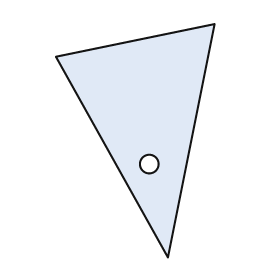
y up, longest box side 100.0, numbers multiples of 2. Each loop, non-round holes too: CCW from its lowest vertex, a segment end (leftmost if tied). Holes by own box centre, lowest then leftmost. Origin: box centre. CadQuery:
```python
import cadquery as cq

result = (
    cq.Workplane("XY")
    .moveTo(14.0, -50.0)
    .lineTo(34.0, 50.0)
    .lineTo(-34.0, 36.0)
    .close()
    .moveTo(6.0, -10.0)
    .circle(4.0)
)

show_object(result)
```